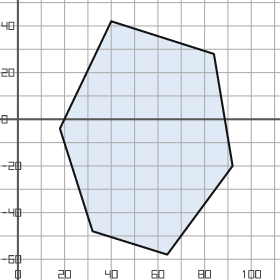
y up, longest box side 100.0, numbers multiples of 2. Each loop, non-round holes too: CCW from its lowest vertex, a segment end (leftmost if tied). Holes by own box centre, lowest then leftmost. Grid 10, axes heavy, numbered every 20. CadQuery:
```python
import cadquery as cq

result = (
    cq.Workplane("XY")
    .moveTo(64.0, -58.0)
    .lineTo(92.0, -20.0)
    .lineTo(84.0, 28.0)
    .lineTo(40.0, 42.0)
    .lineTo(18.0, -4.0)
    .lineTo(32.0, -48.0)
    .close()
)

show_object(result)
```